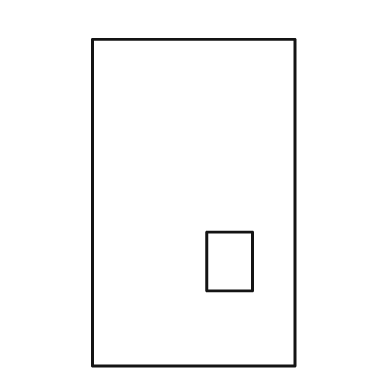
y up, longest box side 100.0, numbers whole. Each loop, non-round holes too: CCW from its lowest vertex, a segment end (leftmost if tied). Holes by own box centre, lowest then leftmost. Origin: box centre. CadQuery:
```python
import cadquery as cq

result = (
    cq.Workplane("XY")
    .moveTo(-31.0, -50.0)
    .lineTo(31.0, -50.0)
    .lineTo(31.0, 50.0)
    .lineTo(-31.0, 50.0)
    .close()
    .moveTo(4.0, -27.0)
    .lineTo(18.0, -27.0)
    .lineTo(18.0, -9.0)
    .lineTo(4.0, -9.0)
    .close()
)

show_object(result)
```